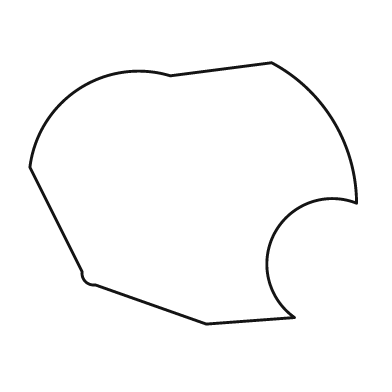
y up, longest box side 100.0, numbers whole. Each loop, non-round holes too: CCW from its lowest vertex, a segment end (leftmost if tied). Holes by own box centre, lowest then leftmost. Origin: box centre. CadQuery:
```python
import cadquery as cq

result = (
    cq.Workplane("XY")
    .moveTo(4.0, -40.0)
    .lineTo(31.0, -38.0)
    .threePointArc((25.0, -12.0), (50.0, -3.0))
    .threePointArc((43.0, 22.0), (24.0, 40.0))
    .lineTo(-7.0, 36.0)
    .threePointArc((-35.0, 32.0), (-50.0, 8.0))
    .lineTo(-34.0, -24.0)
    .threePointArc((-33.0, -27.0), (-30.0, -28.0))
    .close()
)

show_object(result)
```